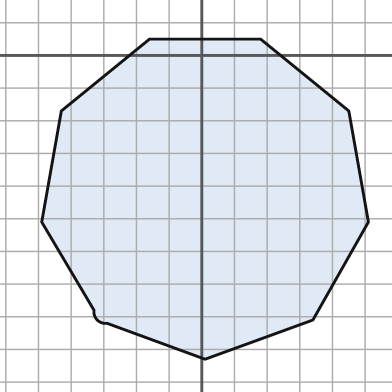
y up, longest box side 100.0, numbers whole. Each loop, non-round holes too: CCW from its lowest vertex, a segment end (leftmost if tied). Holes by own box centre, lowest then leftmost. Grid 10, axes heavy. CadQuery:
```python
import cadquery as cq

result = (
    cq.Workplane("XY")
    .moveTo(1.0, -93.0)
    .lineTo(34.0, -81.0)
    .lineTo(51.0, -51.0)
    .lineTo(45.0, -17.0)
    .lineTo(18.0, 5.0)
    .lineTo(-16.0, 5.0)
    .lineTo(-43.0, -17.0)
    .lineTo(-49.0, -51.0)
    .lineTo(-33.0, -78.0)
    .threePointArc((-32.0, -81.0), (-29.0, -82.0))
    .close()
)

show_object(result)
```